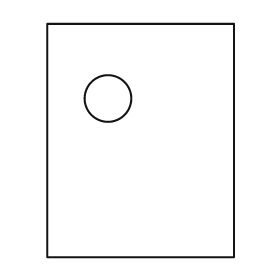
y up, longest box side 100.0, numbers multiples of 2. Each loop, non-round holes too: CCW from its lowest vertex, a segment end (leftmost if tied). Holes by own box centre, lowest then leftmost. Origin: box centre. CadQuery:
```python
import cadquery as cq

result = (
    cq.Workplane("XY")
    .moveTo(-40.0, -50.0)
    .lineTo(40.0, -50.0)
    .lineTo(40.0, 50.0)
    .lineTo(-40.0, 50.0)
    .close()
    .moveTo(-14.0, 18.0)
    .circle(10.0)
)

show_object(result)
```